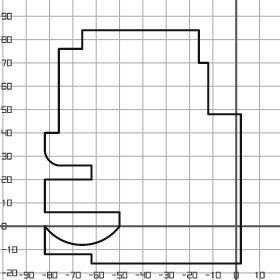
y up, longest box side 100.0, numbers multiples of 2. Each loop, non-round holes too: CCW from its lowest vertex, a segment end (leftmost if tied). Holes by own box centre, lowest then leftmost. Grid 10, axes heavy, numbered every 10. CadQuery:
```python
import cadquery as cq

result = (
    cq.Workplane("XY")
    .moveTo(-62.0, -16.0)
    .lineTo(2.0, -16.0)
    .lineTo(2.0, 48.0)
    .lineTo(-12.0, 48.0)
    .lineTo(-12.0, 70.0)
    .lineTo(-16.0, 70.0)
    .lineTo(-16.0, 84.0)
    .lineTo(-66.0, 84.0)
    .lineTo(-66.0, 76.0)
    .lineTo(-76.0, 76.0)
    .lineTo(-76.0, 40.0)
    .lineTo(-82.0, 40.0)
    .lineTo(-82.0, 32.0)
    .threePointArc((-80.0, 28.0), (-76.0, 26.0))
    .lineTo(-62.0, 26.0)
    .lineTo(-62.0, 20.0)
    .lineTo(-82.0, 20.0)
    .lineTo(-82.0, 6.0)
    .lineTo(-50.0, 6.0)
    .lineTo(-50.0, 0.0)
    .threePointArc((-66.0, -8.0), (-82.0, 0.0))
    .lineTo(-82.0, -12.0)
    .lineTo(-62.0, -12.0)
    .close()
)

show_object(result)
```